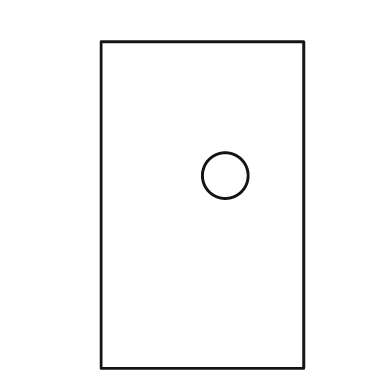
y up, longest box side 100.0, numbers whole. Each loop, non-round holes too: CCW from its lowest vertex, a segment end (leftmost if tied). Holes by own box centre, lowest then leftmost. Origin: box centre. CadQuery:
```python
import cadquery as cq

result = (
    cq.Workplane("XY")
    .moveTo(-31.0, -50.0)
    .lineTo(31.0, -50.0)
    .lineTo(31.0, 50.0)
    .lineTo(-31.0, 50.0)
    .close()
    .moveTo(7.0, 9.0)
    .circle(7.0)
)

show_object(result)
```